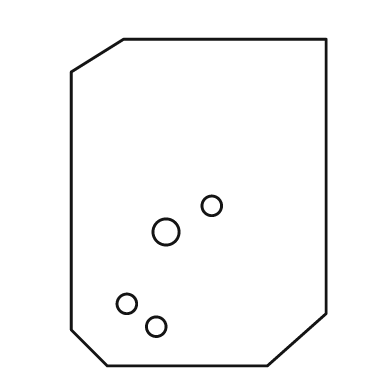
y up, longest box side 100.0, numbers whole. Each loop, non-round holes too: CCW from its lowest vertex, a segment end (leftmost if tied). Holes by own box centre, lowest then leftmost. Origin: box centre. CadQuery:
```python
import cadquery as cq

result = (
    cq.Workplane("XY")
    .moveTo(-28.0, -50.0)
    .lineTo(21.0, -50.0)
    .lineTo(39.0, -34.0)
    .lineTo(39.0, 50.0)
    .lineTo(-23.0, 50.0)
    .lineTo(-39.0, 40.0)
    .lineTo(-39.0, -39.0)
    .close()
    .moveTo(-13.0, -38.0)
    .circle(3.0)
    .moveTo(-22.0, -31.0)
    .circle(3.0)
    .moveTo(-10.0, -9.0)
    .circle(4.0)
    .moveTo(4.0, -1.0)
    .circle(3.0)
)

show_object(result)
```